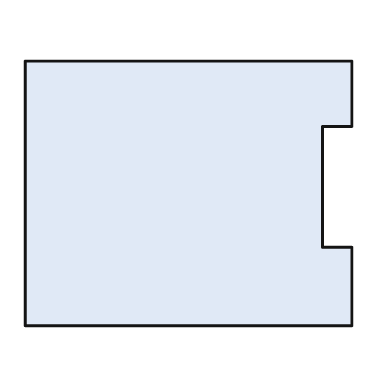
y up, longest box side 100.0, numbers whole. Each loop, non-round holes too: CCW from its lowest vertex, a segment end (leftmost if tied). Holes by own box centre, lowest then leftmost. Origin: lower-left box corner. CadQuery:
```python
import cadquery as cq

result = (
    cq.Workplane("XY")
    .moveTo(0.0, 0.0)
    .lineTo(100.0, 0.0)
    .lineTo(100.0, 24.0)
    .lineTo(91.0, 24.0)
    .lineTo(91.0, 61.0)
    .lineTo(100.0, 61.0)
    .lineTo(100.0, 81.0)
    .lineTo(0.0, 81.0)
    .close()
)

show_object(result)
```